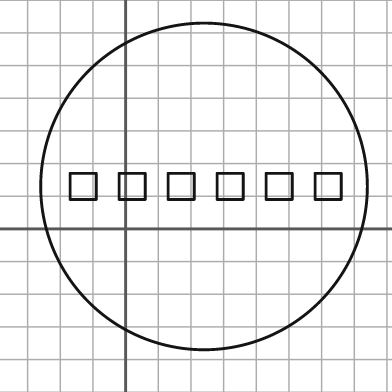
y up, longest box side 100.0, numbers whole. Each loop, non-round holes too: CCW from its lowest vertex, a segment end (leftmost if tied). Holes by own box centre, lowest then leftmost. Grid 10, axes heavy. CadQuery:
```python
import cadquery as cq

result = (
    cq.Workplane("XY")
    .moveTo(24.0, 13.0)
    .circle(50.0)
    .moveTo(-17.0, 9.0)
    .lineTo(-9.0, 9.0)
    .lineTo(-9.0, 17.0)
    .lineTo(-17.0, 17.0)
    .close()
    .moveTo(-2.0, 9.0)
    .lineTo(6.0, 9.0)
    .lineTo(6.0, 17.0)
    .lineTo(-2.0, 17.0)
    .close()
    .moveTo(13.0, 9.0)
    .lineTo(21.0, 9.0)
    .lineTo(21.0, 17.0)
    .lineTo(13.0, 17.0)
    .close()
    .moveTo(28.0, 9.0)
    .lineTo(36.0, 9.0)
    .lineTo(36.0, 17.0)
    .lineTo(28.0, 17.0)
    .close()
    .moveTo(43.0, 9.0)
    .lineTo(51.0, 9.0)
    .lineTo(51.0, 17.0)
    .lineTo(43.0, 17.0)
    .close()
    .moveTo(58.0, 9.0)
    .lineTo(66.0, 9.0)
    .lineTo(66.0, 17.0)
    .lineTo(58.0, 17.0)
    .close()
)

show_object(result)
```